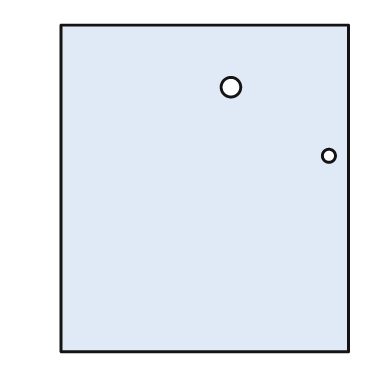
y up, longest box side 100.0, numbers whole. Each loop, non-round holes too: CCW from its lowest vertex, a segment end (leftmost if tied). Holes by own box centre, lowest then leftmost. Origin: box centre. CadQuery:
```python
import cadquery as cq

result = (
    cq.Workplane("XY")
    .moveTo(-44.0, -50.0)
    .lineTo(44.0, -50.0)
    .lineTo(44.0, 50.0)
    .lineTo(-44.0, 50.0)
    .close()
    .moveTo(38.0, 10.0)
    .circle(2.0)
    .moveTo(8.0, 31.0)
    .circle(3.0)
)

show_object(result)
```